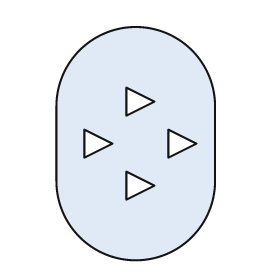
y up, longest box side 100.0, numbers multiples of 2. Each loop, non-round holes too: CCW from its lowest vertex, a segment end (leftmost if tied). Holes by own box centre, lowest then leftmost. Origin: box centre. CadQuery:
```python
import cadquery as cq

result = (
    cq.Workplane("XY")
    .moveTo(-34.0, -16.0)
    .threePointArc((0.0, -50.0), (34.0, -16.0))
    .lineTo(34.0, 16.0)
    .threePointArc((0.0, 50.0), (-34.0, 16.0))
    .close()
    .moveTo(-4.0, -24.0)
    .lineTo(8.0, -18.0)
    .lineTo(-4.0, -12.0)
    .close()
    .moveTo(-22.0, -6.0)
    .lineTo(-10.0, 0.0)
    .lineTo(-22.0, 6.0)
    .close()
    .moveTo(14.0, -6.0)
    .lineTo(26.0, 0.0)
    .lineTo(14.0, 6.0)
    .close()
    .moveTo(-4.0, 12.0)
    .lineTo(8.0, 18.0)
    .lineTo(-4.0, 24.0)
    .close()
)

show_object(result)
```